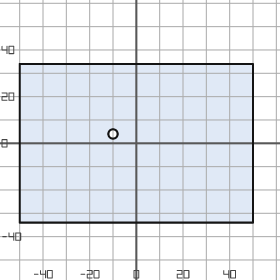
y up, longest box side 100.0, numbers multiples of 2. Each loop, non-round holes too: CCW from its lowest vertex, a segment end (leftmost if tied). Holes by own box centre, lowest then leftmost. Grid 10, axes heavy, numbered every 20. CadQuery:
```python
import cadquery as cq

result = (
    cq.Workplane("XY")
    .moveTo(-50.0, -34.0)
    .lineTo(50.0, -34.0)
    .lineTo(50.0, 34.0)
    .lineTo(-50.0, 34.0)
    .close()
    .moveTo(-10.0, 4.0)
    .circle(2.0)
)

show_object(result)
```